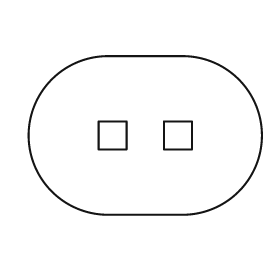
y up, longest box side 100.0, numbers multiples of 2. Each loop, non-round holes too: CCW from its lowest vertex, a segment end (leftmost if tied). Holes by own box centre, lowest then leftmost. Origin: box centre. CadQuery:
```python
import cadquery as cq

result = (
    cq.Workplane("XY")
    .moveTo(-16.0, -34.0)
    .lineTo(16.0, -34.0)
    .threePointArc((50.0, 0.0), (16.0, 34.0))
    .lineTo(-16.0, 34.0)
    .threePointArc((-50.0, 0.0), (-16.0, -34.0))
    .close()
    .moveTo(-20.0, -6.0)
    .lineTo(-8.0, -6.0)
    .lineTo(-8.0, 6.0)
    .lineTo(-20.0, 6.0)
    .close()
    .moveTo(8.0, -6.0)
    .lineTo(20.0, -6.0)
    .lineTo(20.0, 6.0)
    .lineTo(8.0, 6.0)
    .close()
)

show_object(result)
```